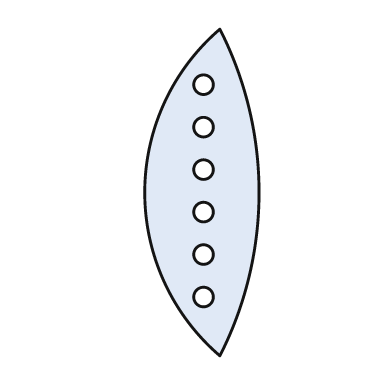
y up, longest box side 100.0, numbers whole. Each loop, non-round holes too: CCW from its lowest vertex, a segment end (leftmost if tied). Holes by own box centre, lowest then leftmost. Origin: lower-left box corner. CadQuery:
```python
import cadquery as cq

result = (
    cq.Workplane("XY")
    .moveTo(23.0, 0.0)
    .threePointArc((35.0, 50.0), (23.0, 100.0))
    .threePointArc((0.0, 50.0), (23.0, 0.0))
    .close()
    .moveTo(18.0, 18.0)
    .circle(3.0)
    .moveTo(18.0, 31.0)
    .circle(3.0)
    .moveTo(18.0, 44.0)
    .circle(3.0)
    .moveTo(18.0, 57.0)
    .circle(3.0)
    .moveTo(18.0, 70.0)
    .circle(3.0)
    .moveTo(18.0, 83.0)
    .circle(3.0)
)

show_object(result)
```